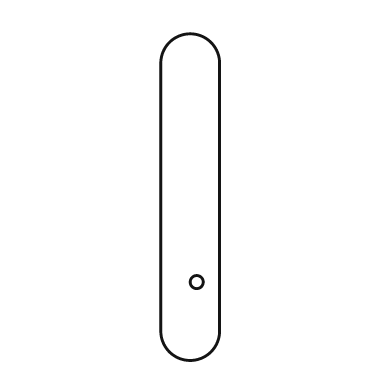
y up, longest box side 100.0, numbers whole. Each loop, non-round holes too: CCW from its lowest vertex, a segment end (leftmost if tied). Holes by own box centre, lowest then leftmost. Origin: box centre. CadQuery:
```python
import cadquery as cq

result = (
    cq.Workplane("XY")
    .moveTo(-9.0, -41.0)
    .threePointArc((0.0, -50.0), (9.0, -41.0))
    .lineTo(9.0, 41.0)
    .threePointArc((0.0, 50.0), (-9.0, 41.0))
    .close()
    .moveTo(2.0, -26.0)
    .circle(2.0)
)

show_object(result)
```